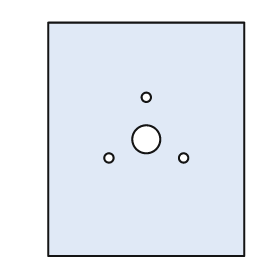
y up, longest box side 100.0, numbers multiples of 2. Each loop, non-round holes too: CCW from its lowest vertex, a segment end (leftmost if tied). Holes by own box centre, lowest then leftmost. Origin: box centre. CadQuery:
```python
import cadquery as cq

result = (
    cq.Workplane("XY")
    .moveTo(-42.0, -50.0)
    .lineTo(42.0, -50.0)
    .lineTo(42.0, 50.0)
    .lineTo(-42.0, 50.0)
    .close()
    .moveTo(-16.0, -8.0)
    .circle(2.0)
    .moveTo(16.0, -8.0)
    .circle(2.0)
    .moveTo(0.0, 0.0)
    .circle(6.0)
    .moveTo(0.0, 18.0)
    .circle(2.0)
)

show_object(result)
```